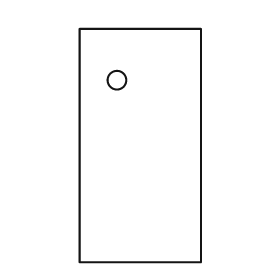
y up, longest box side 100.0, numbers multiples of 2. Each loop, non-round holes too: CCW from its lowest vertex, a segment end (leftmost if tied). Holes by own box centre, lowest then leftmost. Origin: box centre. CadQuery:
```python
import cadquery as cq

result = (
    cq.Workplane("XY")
    .moveTo(-26.0, -50.0)
    .lineTo(26.0, -50.0)
    .lineTo(26.0, 50.0)
    .lineTo(-26.0, 50.0)
    .close()
    .moveTo(-10.0, 28.0)
    .circle(4.0)
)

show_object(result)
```